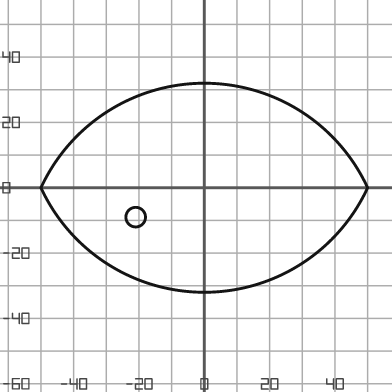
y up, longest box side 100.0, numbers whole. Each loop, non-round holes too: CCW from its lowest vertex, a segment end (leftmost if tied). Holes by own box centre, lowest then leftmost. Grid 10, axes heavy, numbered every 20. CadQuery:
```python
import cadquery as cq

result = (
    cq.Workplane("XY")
    .moveTo(-50.0, 0.0)
    .threePointArc((0.0, -32.0), (50.0, 0.0))
    .threePointArc((0.0, 32.0), (-50.0, 0.0))
    .close()
    .moveTo(-21.0, -9.0)
    .circle(3.0)
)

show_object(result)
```